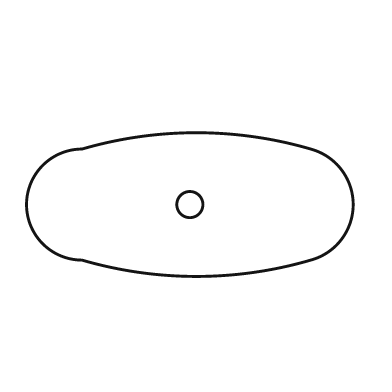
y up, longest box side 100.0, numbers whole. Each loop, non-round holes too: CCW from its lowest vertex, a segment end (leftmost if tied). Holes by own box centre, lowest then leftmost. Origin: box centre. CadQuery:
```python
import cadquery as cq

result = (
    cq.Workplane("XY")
    .moveTo(-33.0, -17.0)
    .threePointArc((2.0, -22.0), (37.0, -17.0))
    .threePointArc((50.0, 0.0), (37.0, 17.0))
    .threePointArc((2.0, 22.0), (-33.0, 17.0))
    .threePointArc((-50.0, 0.0), (-33.0, -17.0))
    .close()
    .moveTo(0.0, 0.0)
    .circle(4.0)
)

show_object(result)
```